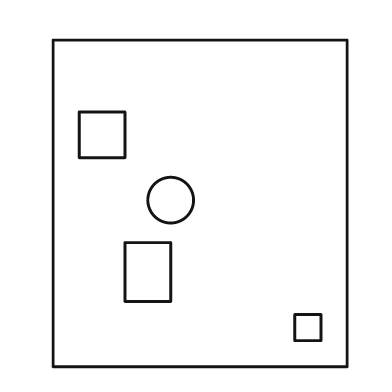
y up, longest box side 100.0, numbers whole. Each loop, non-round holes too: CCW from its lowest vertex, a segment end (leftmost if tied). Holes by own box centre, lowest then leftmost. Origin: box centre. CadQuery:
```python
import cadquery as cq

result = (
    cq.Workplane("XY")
    .moveTo(-45.0, -50.0)
    .lineTo(45.0, -50.0)
    .lineTo(45.0, 50.0)
    .lineTo(-45.0, 50.0)
    .close()
    .moveTo(29.0, -42.0)
    .lineTo(37.0, -42.0)
    .lineTo(37.0, -34.0)
    .lineTo(29.0, -34.0)
    .close()
    .moveTo(-23.0, -30.0)
    .lineTo(-9.0, -30.0)
    .lineTo(-9.0, -12.0)
    .lineTo(-23.0, -12.0)
    .close()
    .moveTo(-9.0, 1.0)
    .circle(7.0)
    .moveTo(-37.0, 14.0)
    .lineTo(-23.0, 14.0)
    .lineTo(-23.0, 28.0)
    .lineTo(-37.0, 28.0)
    .close()
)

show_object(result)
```